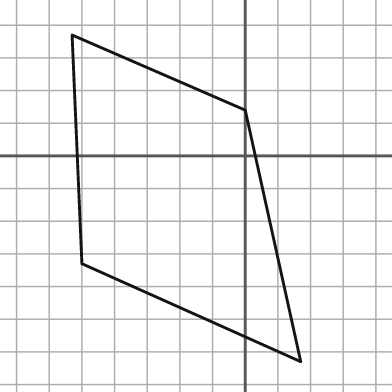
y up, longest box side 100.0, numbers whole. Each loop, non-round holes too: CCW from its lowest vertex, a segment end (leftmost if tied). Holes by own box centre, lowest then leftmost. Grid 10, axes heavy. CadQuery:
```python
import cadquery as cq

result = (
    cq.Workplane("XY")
    .moveTo(17.0, -63.0)
    .lineTo(0.0, 14.0)
    .lineTo(-53.0, 37.0)
    .lineTo(-50.0, -33.0)
    .close()
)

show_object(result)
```